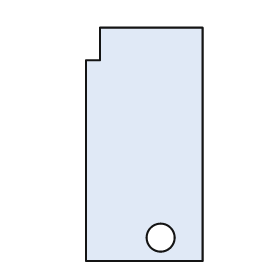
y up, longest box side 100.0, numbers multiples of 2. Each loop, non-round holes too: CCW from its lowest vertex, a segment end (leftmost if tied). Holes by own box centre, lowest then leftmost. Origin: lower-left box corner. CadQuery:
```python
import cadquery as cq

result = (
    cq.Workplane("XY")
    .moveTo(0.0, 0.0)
    .lineTo(50.0, 0.0)
    .lineTo(50.0, 100.0)
    .lineTo(6.0, 100.0)
    .lineTo(6.0, 86.0)
    .lineTo(0.0, 86.0)
    .close()
    .moveTo(32.0, 10.0)
    .circle(6.0)
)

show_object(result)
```